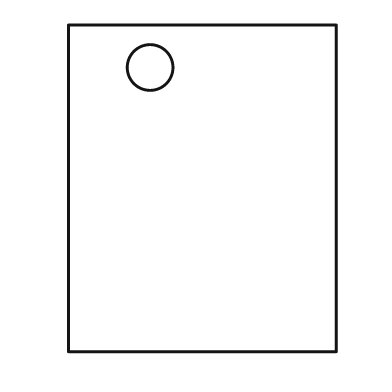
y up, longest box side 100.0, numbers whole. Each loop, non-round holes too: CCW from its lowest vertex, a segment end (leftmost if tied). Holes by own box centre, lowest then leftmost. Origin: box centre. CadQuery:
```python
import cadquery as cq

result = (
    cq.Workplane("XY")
    .moveTo(-41.0, -50.0)
    .lineTo(41.0, -50.0)
    .lineTo(41.0, 50.0)
    .lineTo(-41.0, 50.0)
    .close()
    .moveTo(-16.0, 37.0)
    .circle(7.0)
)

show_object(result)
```